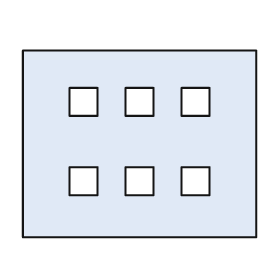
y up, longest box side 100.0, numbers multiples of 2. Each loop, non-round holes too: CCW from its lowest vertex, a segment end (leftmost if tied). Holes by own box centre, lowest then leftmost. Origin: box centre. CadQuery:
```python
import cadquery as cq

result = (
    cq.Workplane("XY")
    .moveTo(-50.0, -40.0)
    .lineTo(50.0, -40.0)
    .lineTo(50.0, 40.0)
    .lineTo(-50.0, 40.0)
    .close()
    .moveTo(-30.0, -22.0)
    .lineTo(-18.0, -22.0)
    .lineTo(-18.0, -10.0)
    .lineTo(-30.0, -10.0)
    .close()
    .moveTo(-6.0, -22.0)
    .lineTo(6.0, -22.0)
    .lineTo(6.0, -10.0)
    .lineTo(-6.0, -10.0)
    .close()
    .moveTo(18.0, -22.0)
    .lineTo(30.0, -22.0)
    .lineTo(30.0, -10.0)
    .lineTo(18.0, -10.0)
    .close()
    .moveTo(-30.0, 12.0)
    .lineTo(-18.0, 12.0)
    .lineTo(-18.0, 24.0)
    .lineTo(-30.0, 24.0)
    .close()
    .moveTo(-6.0, 12.0)
    .lineTo(6.0, 12.0)
    .lineTo(6.0, 24.0)
    .lineTo(-6.0, 24.0)
    .close()
    .moveTo(18.0, 12.0)
    .lineTo(30.0, 12.0)
    .lineTo(30.0, 24.0)
    .lineTo(18.0, 24.0)
    .close()
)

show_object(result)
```